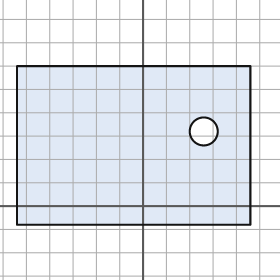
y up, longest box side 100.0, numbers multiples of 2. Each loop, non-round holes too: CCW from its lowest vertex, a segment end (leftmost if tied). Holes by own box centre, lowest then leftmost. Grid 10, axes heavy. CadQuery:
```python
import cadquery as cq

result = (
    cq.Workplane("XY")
    .moveTo(-54.0, -8.0)
    .lineTo(46.0, -8.0)
    .lineTo(46.0, 60.0)
    .lineTo(-54.0, 60.0)
    .close()
    .moveTo(26.0, 32.0)
    .circle(6.0)
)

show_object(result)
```